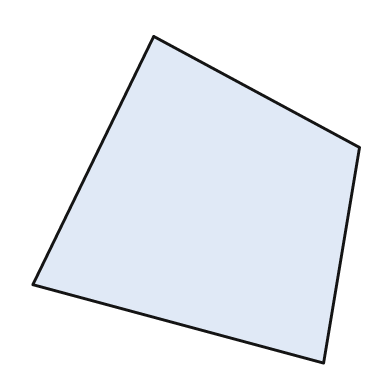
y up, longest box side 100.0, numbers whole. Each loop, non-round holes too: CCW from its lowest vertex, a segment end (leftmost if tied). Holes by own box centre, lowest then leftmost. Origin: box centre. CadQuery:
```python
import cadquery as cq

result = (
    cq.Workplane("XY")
    .moveTo(39.0, -50.0)
    .lineTo(50.0, 16.0)
    .lineTo(-13.0, 50.0)
    .lineTo(-50.0, -26.0)
    .close()
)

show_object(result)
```